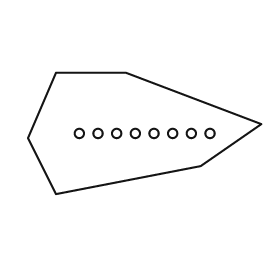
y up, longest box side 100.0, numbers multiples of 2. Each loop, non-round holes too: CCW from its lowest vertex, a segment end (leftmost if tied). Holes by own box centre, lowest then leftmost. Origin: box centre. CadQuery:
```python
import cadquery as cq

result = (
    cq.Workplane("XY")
    .moveTo(-38.0, -26.0)
    .lineTo(24.0, -14.0)
    .lineTo(50.0, 4.0)
    .lineTo(-8.0, 26.0)
    .lineTo(-38.0, 26.0)
    .lineTo(-50.0, -2.0)
    .close()
    .moveTo(-28.0, 0.0)
    .circle(2.0)
    .moveTo(-20.0, 0.0)
    .circle(2.0)
    .moveTo(-12.0, 0.0)
    .circle(2.0)
    .moveTo(-4.0, 0.0)
    .circle(2.0)
    .moveTo(4.0, 0.0)
    .circle(2.0)
    .moveTo(12.0, 0.0)
    .circle(2.0)
    .moveTo(20.0, 0.0)
    .circle(2.0)
    .moveTo(28.0, 0.0)
    .circle(2.0)
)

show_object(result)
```